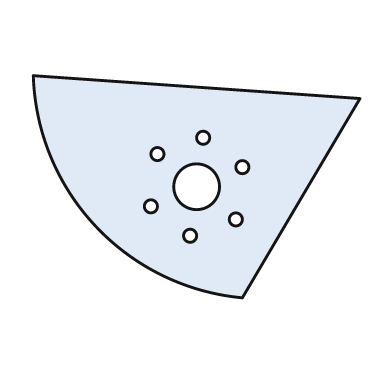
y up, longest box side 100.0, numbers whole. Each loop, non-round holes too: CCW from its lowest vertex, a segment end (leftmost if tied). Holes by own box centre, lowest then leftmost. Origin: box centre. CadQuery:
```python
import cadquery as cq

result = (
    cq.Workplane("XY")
    .moveTo(14.0, -34.0)
    .lineTo(50.0, 27.0)
    .lineTo(-50.0, 34.0)
    .threePointArc((-31.0, -12.0), (14.0, -34.0))
    .close()
    .moveTo(-2.0, -15.0)
    .circle(2.0)
    .moveTo(12.0, -10.0)
    .circle(2.0)
    .moveTo(-14.0, -6.0)
    .circle(2.0)
    .moveTo(0.0, 0.0)
    .circle(7.0)
    .moveTo(14.0, 6.0)
    .circle(2.0)
    .moveTo(-12.0, 10.0)
    .circle(2.0)
    .moveTo(2.0, 15.0)
    .circle(2.0)
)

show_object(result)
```